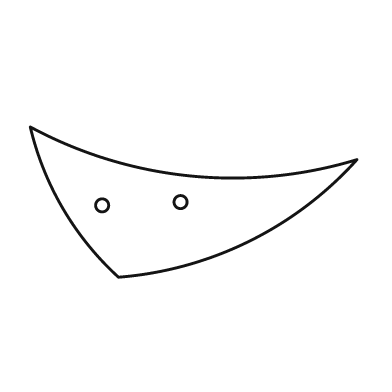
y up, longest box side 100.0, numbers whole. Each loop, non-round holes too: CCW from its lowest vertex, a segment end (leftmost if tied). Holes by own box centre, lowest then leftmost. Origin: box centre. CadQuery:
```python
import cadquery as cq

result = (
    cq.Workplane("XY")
    .moveTo(-23.0, -23.0)
    .threePointArc((17.0, -12.0), (50.0, 13.0))
    .threePointArc((-1.0, 8.0), (-50.0, 23.0))
    .threePointArc((-40.0, -2.0), (-23.0, -23.0))
    .close()
    .moveTo(-28.0, -1.0)
    .circle(2.0)
    .moveTo(-4.0, 0.0)
    .circle(2.0)
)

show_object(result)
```